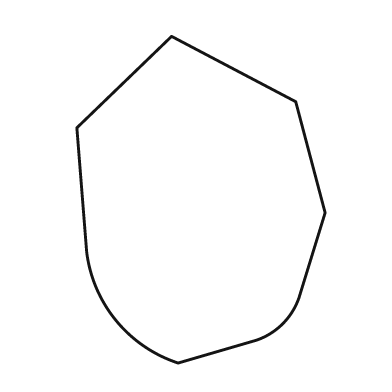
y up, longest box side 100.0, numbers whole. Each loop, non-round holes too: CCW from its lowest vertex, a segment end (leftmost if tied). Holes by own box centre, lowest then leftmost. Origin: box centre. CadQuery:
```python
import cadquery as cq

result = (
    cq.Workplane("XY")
    .moveTo(-7.0, -50.0)
    .lineTo(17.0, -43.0)
    .threePointArc((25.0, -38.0), (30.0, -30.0))
    .lineTo(38.0, -4.0)
    .lineTo(29.0, 30.0)
    .lineTo(-9.0, 50.0)
    .lineTo(-38.0, 22.0)
    .lineTo(-35.0, -16.0)
    .threePointArc((-26.0, -37.0), (-7.0, -50.0))
    .close()
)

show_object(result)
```